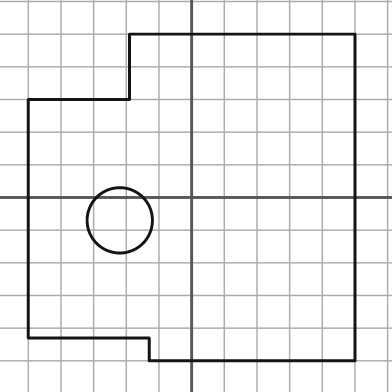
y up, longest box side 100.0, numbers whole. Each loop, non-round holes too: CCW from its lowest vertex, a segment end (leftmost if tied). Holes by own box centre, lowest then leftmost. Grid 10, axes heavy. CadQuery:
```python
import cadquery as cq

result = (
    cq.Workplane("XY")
    .moveTo(-13.0, -50.0)
    .lineTo(50.0, -50.0)
    .lineTo(50.0, 50.0)
    .lineTo(-19.0, 50.0)
    .lineTo(-19.0, 30.0)
    .lineTo(-50.0, 30.0)
    .lineTo(-50.0, -43.0)
    .lineTo(-13.0, -43.0)
    .close()
    .moveTo(-22.0, -7.0)
    .circle(10.0)
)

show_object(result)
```